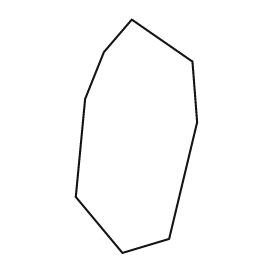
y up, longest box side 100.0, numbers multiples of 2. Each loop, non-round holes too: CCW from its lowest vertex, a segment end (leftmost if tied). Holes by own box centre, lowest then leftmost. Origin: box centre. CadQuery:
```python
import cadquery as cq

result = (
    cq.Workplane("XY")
    .moveTo(-6.0, -50.0)
    .lineTo(14.0, -44.0)
    .lineTo(26.0, 6.0)
    .lineTo(24.0, 32.0)
    .lineTo(-2.0, 50.0)
    .lineTo(-14.0, 36.0)
    .lineTo(-22.0, 16.0)
    .lineTo(-26.0, -26.0)
    .close()
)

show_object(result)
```